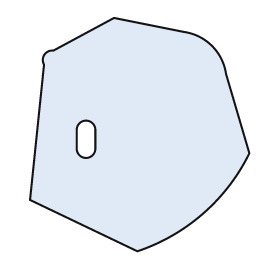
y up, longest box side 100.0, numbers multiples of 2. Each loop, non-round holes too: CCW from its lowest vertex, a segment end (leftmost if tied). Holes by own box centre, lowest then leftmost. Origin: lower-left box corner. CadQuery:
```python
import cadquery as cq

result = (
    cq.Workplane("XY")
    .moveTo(46.0, 0.0)
    .threePointArc((74.0, 16.0), (94.0, 42.0))
    .lineTo(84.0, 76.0)
    .threePointArc((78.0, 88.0), (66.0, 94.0))
    .lineTo(36.0, 100.0)
    .lineTo(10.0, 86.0)
    .threePointArc((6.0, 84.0), (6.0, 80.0))
    .lineTo(0.0, 22.0)
    .close()
    .moveTo(20.0, 44.0)
    .threePointArc((24.0, 40.0), (28.0, 44.0))
    .lineTo(28.0, 52.0)
    .threePointArc((24.0, 56.0), (20.0, 52.0))
    .close()
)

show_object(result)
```